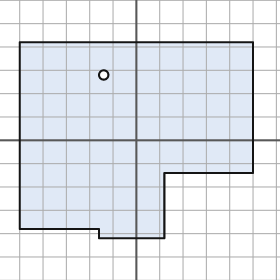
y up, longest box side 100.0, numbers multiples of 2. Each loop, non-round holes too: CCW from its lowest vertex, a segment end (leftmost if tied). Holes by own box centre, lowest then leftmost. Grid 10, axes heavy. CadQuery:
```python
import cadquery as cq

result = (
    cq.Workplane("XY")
    .moveTo(-16.0, -42.0)
    .lineTo(12.0, -42.0)
    .lineTo(12.0, -14.0)
    .lineTo(50.0, -14.0)
    .lineTo(50.0, 42.0)
    .lineTo(-50.0, 42.0)
    .lineTo(-50.0, -38.0)
    .lineTo(-16.0, -38.0)
    .close()
    .moveTo(-14.0, 28.0)
    .circle(2.0)
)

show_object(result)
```